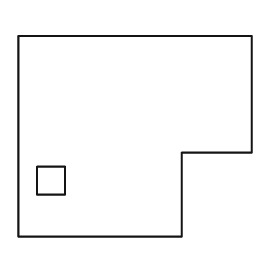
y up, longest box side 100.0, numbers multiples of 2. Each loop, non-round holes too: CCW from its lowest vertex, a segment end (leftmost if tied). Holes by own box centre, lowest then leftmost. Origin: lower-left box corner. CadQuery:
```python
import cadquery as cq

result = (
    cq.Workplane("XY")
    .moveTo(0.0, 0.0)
    .lineTo(70.0, 0.0)
    .lineTo(70.0, 36.0)
    .lineTo(100.0, 36.0)
    .lineTo(100.0, 86.0)
    .lineTo(0.0, 86.0)
    .close()
    .moveTo(8.0, 18.0)
    .lineTo(20.0, 18.0)
    .lineTo(20.0, 30.0)
    .lineTo(8.0, 30.0)
    .close()
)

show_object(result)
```